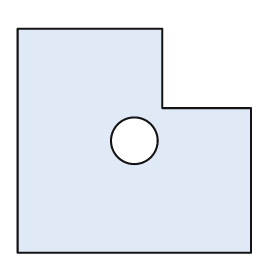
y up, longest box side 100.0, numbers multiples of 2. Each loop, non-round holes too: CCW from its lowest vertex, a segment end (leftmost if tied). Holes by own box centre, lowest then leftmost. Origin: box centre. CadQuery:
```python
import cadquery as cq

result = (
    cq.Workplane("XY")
    .moveTo(-50.0, -48.0)
    .lineTo(50.0, -48.0)
    .lineTo(50.0, 14.0)
    .lineTo(12.0, 14.0)
    .lineTo(12.0, 48.0)
    .lineTo(-50.0, 48.0)
    .close()
    .moveTo(0.0, 0.0)
    .circle(10.0)
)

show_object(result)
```